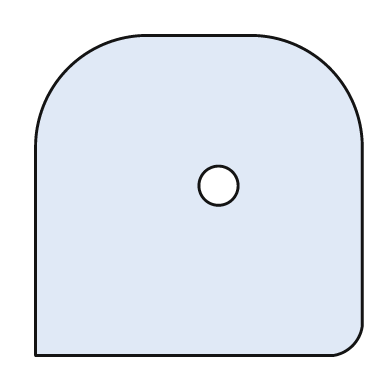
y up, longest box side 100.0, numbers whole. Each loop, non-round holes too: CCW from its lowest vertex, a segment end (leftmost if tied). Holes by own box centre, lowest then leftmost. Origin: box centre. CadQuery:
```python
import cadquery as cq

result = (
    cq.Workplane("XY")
    .moveTo(-50.0, -49.0)
    .lineTo(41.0, -49.0)
    .threePointArc((47.0, -46.0), (50.0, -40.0))
    .lineTo(50.0, 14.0)
    .threePointArc((40.0, 39.0), (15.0, 49.0))
    .lineTo(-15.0, 49.0)
    .threePointArc((-40.0, 39.0), (-50.0, 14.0))
    .close()
    .moveTo(6.0, 3.0)
    .circle(6.0)
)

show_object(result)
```